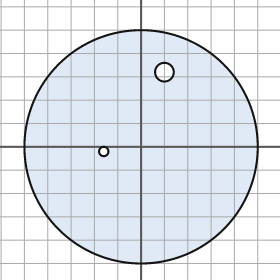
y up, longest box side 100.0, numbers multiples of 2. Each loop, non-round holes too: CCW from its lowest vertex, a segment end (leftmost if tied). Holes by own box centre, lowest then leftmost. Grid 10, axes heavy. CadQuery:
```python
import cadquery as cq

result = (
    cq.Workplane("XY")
    .moveTo(0.0, 0.0)
    .circle(50.0)
    .moveTo(-16.0, -2.0)
    .circle(2.0)
    .moveTo(10.0, 32.0)
    .circle(4.0)
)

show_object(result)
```